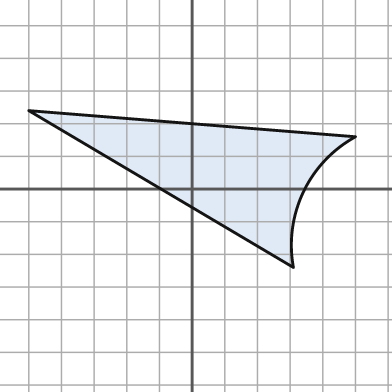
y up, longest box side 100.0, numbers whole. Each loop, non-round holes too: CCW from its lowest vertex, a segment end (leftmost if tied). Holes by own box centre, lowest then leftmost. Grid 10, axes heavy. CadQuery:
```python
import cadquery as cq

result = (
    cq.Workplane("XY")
    .moveTo(31.0, -24.0)
    .threePointArc((34.0, -1.0), (50.0, 16.0))
    .lineTo(-50.0, 24.0)
    .close()
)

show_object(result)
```